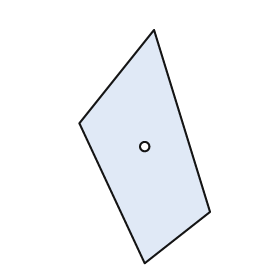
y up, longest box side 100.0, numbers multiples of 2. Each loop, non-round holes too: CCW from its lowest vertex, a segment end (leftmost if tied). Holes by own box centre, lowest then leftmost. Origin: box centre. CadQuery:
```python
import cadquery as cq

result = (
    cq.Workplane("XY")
    .moveTo(0.0, -50.0)
    .lineTo(28.0, -28.0)
    .lineTo(4.0, 50.0)
    .lineTo(-28.0, 10.0)
    .close()
    .moveTo(0.0, 0.0)
    .circle(2.0)
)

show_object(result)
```